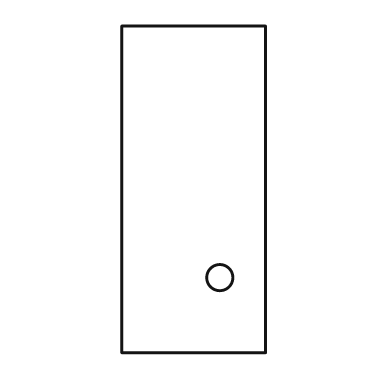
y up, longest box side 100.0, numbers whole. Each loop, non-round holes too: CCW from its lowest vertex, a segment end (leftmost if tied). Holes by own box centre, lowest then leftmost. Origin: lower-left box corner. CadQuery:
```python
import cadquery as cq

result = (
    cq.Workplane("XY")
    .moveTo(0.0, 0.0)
    .lineTo(44.0, 0.0)
    .lineTo(44.0, 100.0)
    .lineTo(0.0, 100.0)
    .close()
    .moveTo(30.0, 23.0)
    .circle(4.0)
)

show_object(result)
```